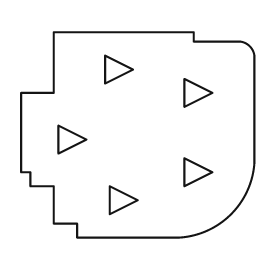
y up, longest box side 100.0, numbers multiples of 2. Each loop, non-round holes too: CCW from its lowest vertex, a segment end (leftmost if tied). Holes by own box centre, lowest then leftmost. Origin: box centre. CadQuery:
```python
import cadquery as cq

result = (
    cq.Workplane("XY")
    .moveTo(-26.0, -44.0)
    .lineTo(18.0, -44.0)
    .threePointArc((40.0, -34.0), (50.0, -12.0))
    .lineTo(50.0, 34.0)
    .threePointArc((48.0, 38.0), (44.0, 40.0))
    .lineTo(24.0, 40.0)
    .lineTo(24.0, 44.0)
    .lineTo(-36.0, 44.0)
    .lineTo(-36.0, 18.0)
    .lineTo(-50.0, 18.0)
    .lineTo(-50.0, -16.0)
    .lineTo(-46.0, -16.0)
    .lineTo(-46.0, -22.0)
    .lineTo(-36.0, -22.0)
    .lineTo(-36.0, -38.0)
    .lineTo(-26.0, -38.0)
    .close()
    .moveTo(-12.0, -34.0)
    .lineTo(0.0, -28.0)
    .lineTo(-12.0, -22.0)
    .close()
    .moveTo(20.0, -22.0)
    .lineTo(32.0, -16.0)
    .lineTo(20.0, -10.0)
    .close()
    .moveTo(-34.0, -8.0)
    .lineTo(-22.0, -2.0)
    .lineTo(-34.0, 4.0)
    .close()
    .moveTo(20.0, 12.0)
    .lineTo(32.0, 18.0)
    .lineTo(20.0, 24.0)
    .close()
    .moveTo(-14.0, 22.0)
    .lineTo(-2.0, 28.0)
    .lineTo(-14.0, 34.0)
    .close()
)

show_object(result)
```